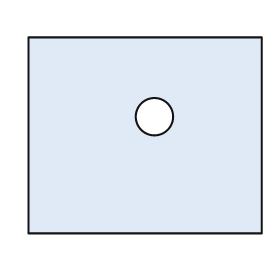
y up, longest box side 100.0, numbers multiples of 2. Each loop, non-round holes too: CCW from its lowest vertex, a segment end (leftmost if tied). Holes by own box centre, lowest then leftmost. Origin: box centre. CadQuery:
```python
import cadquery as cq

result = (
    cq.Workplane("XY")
    .moveTo(-50.0, -42.0)
    .lineTo(50.0, -42.0)
    .lineTo(50.0, 42.0)
    .lineTo(-50.0, 42.0)
    .close()
    .moveTo(4.0, 8.0)
    .circle(8.0)
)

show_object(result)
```